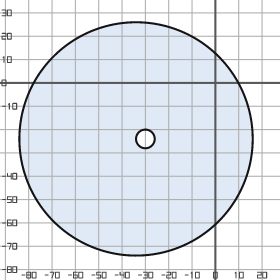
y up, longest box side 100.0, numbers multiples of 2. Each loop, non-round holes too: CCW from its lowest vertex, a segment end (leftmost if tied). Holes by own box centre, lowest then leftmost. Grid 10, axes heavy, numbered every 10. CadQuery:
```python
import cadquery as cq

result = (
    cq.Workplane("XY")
    .moveTo(-34.0, -24.0)
    .circle(50.0)
    .moveTo(-30.0, -24.0)
    .circle(4.0)
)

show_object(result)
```